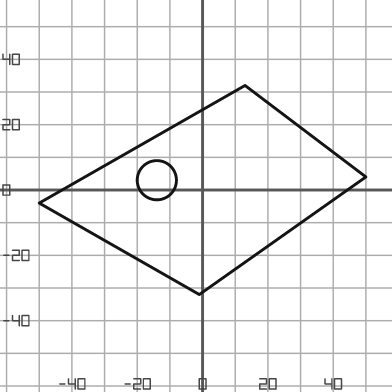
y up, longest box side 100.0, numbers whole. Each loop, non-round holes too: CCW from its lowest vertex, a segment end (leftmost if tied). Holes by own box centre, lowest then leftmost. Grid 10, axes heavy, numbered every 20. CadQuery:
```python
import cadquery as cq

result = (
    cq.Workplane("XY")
    .moveTo(-1.0, -32.0)
    .lineTo(50.0, 4.0)
    .lineTo(13.0, 32.0)
    .lineTo(-50.0, -4.0)
    .close()
    .moveTo(-14.0, 3.0)
    .circle(6.0)
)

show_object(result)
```